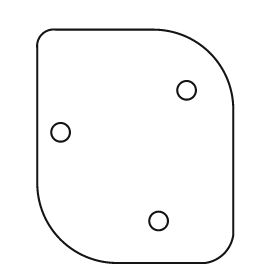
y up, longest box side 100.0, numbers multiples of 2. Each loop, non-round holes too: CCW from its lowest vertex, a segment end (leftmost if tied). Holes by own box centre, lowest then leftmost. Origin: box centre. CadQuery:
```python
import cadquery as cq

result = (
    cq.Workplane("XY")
    .moveTo(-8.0, -50.0)
    .lineTo(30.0, -50.0)
    .threePointArc((38.0, -46.0), (42.0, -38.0))
    .lineTo(42.0, 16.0)
    .threePointArc((32.0, 40.0), (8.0, 50.0))
    .lineTo(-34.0, 50.0)
    .threePointArc((-40.0, 48.0), (-42.0, 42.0))
    .lineTo(-42.0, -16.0)
    .threePointArc((-32.0, -40.0), (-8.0, -50.0))
    .close()
    .moveTo(10.0, -32.0)
    .circle(4.0)
    .moveTo(-32.0, 6.0)
    .circle(4.0)
    .moveTo(22.0, 24.0)
    .circle(4.0)
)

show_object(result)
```